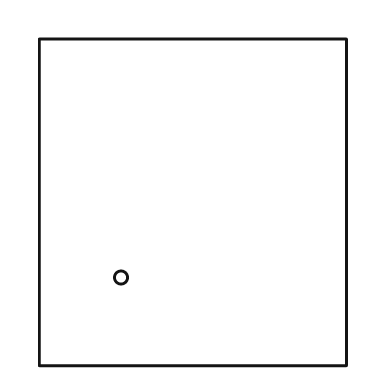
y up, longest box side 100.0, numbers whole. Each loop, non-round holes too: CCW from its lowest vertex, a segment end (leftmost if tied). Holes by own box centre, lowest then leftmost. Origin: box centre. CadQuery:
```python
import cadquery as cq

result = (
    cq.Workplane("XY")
    .moveTo(-47.0, -50.0)
    .lineTo(47.0, -50.0)
    .lineTo(47.0, 50.0)
    .lineTo(-47.0, 50.0)
    .close()
    .moveTo(-22.0, -23.0)
    .circle(2.0)
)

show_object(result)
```